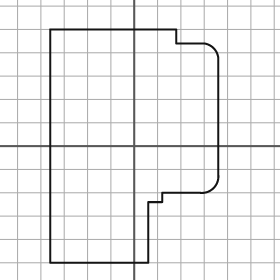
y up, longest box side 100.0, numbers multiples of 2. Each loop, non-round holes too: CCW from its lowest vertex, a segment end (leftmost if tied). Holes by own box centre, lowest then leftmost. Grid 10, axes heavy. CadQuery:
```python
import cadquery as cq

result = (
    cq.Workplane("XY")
    .moveTo(-36.0, -50.0)
    .lineTo(6.0, -50.0)
    .lineTo(6.0, -24.0)
    .lineTo(12.0, -24.0)
    .lineTo(12.0, -20.0)
    .lineTo(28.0, -20.0)
    .threePointArc((34.0, -18.0), (36.0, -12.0))
    .lineTo(36.0, 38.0)
    .threePointArc((34.0, 42.0), (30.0, 44.0))
    .lineTo(18.0, 44.0)
    .lineTo(18.0, 50.0)
    .lineTo(-36.0, 50.0)
    .close()
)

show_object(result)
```